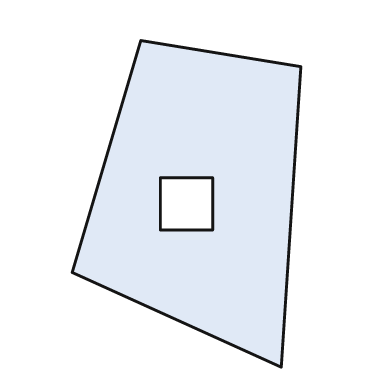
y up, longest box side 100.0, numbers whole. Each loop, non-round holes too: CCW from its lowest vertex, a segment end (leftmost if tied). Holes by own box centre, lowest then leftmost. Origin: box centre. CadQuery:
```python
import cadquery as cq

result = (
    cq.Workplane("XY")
    .moveTo(29.0, -50.0)
    .lineTo(35.0, 42.0)
    .lineTo(-14.0, 50.0)
    .lineTo(-35.0, -21.0)
    .close()
    .moveTo(-8.0, -8.0)
    .lineTo(8.0, -8.0)
    .lineTo(8.0, 8.0)
    .lineTo(-8.0, 8.0)
    .close()
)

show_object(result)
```